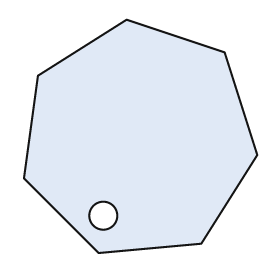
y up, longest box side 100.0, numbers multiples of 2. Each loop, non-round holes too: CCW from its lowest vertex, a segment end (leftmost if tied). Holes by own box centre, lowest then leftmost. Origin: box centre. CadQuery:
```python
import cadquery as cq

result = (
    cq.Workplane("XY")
    .moveTo(-18.0, -50.0)
    .lineTo(26.0, -46.0)
    .lineTo(50.0, -8.0)
    .lineTo(36.0, 36.0)
    .lineTo(-6.0, 50.0)
    .lineTo(-44.0, 26.0)
    .lineTo(-50.0, -18.0)
    .close()
    .moveTo(-16.0, -34.0)
    .circle(6.0)
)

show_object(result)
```